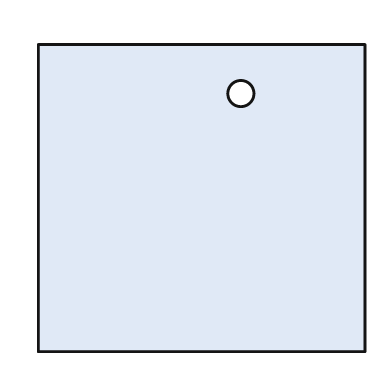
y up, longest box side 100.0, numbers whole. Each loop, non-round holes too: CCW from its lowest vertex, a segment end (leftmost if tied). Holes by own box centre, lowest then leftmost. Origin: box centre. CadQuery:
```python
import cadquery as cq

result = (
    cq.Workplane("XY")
    .moveTo(-50.0, -47.0)
    .lineTo(50.0, -47.0)
    .lineTo(50.0, 47.0)
    .lineTo(-50.0, 47.0)
    .close()
    .moveTo(12.0, 32.0)
    .circle(4.0)
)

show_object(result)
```